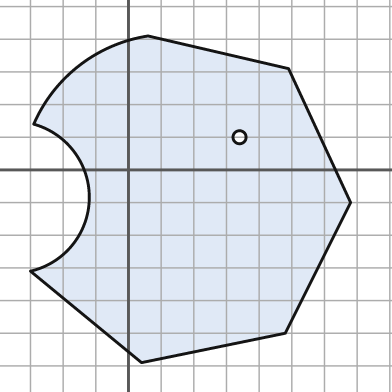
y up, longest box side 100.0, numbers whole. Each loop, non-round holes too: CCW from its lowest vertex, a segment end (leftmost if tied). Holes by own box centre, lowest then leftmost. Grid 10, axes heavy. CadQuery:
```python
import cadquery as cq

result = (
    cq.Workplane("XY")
    .moveTo(4.0, -59.0)
    .lineTo(48.0, -50.0)
    .lineTo(68.0, -10.0)
    .lineTo(49.0, 31.0)
    .lineTo(6.0, 41.0)
    .threePointArc((-15.0, 32.0), (-29.0, 14.0))
    .threePointArc((-12.0, -9.0), (-30.0, -31.0))
    .close()
    .moveTo(34.0, 10.0)
    .circle(2.0)
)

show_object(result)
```